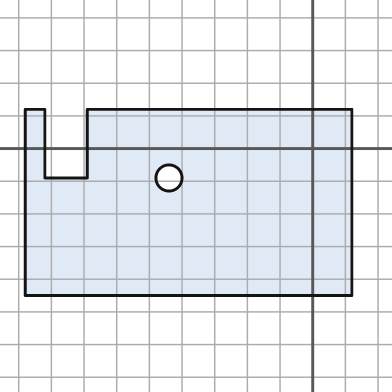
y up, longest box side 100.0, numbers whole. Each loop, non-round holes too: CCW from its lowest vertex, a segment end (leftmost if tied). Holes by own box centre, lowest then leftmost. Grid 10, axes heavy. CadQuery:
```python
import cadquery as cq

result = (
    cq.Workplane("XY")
    .moveTo(-88.0, -45.0)
    .lineTo(12.0, -45.0)
    .lineTo(12.0, 12.0)
    .lineTo(-69.0, 12.0)
    .lineTo(-69.0, -9.0)
    .lineTo(-82.0, -9.0)
    .lineTo(-82.0, 12.0)
    .lineTo(-88.0, 12.0)
    .close()
    .moveTo(-44.0, -9.0)
    .circle(4.0)
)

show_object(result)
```